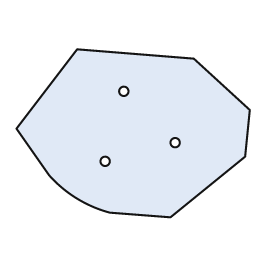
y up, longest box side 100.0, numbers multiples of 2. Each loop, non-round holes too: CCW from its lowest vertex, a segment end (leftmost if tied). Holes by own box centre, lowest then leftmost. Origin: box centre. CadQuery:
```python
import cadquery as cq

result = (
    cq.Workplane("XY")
    .moveTo(16.0, -36.0)
    .lineTo(48.0, -10.0)
    .lineTo(50.0, 10.0)
    .lineTo(26.0, 32.0)
    .lineTo(-24.0, 36.0)
    .lineTo(-50.0, 2.0)
    .lineTo(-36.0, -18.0)
    .threePointArc((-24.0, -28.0), (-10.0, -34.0))
    .close()
    .moveTo(-12.0, -12.0)
    .circle(2.0)
    .moveTo(18.0, -4.0)
    .circle(2.0)
    .moveTo(-4.0, 18.0)
    .circle(2.0)
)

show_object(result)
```